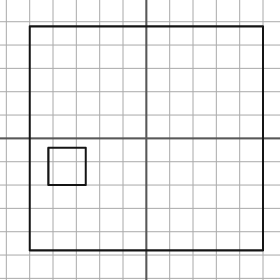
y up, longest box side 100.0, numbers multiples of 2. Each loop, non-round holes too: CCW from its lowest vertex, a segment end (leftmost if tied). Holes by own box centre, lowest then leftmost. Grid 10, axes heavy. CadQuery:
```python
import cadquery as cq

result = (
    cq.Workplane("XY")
    .moveTo(-50.0, -48.0)
    .lineTo(50.0, -48.0)
    .lineTo(50.0, 48.0)
    .lineTo(-50.0, 48.0)
    .close()
    .moveTo(-42.0, -20.0)
    .lineTo(-26.0, -20.0)
    .lineTo(-26.0, -4.0)
    .lineTo(-42.0, -4.0)
    .close()
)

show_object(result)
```